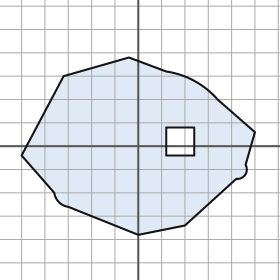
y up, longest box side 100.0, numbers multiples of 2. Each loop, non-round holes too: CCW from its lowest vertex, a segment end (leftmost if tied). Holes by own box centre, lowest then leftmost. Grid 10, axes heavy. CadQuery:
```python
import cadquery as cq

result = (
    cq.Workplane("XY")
    .moveTo(0.0, -38.0)
    .lineTo(20.0, -34.0)
    .lineTo(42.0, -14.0)
    .threePointArc((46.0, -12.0), (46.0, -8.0))
    .lineTo(50.0, 6.0)
    .lineTo(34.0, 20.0)
    .threePointArc((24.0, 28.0), (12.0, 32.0))
    .lineTo(-4.0, 38.0)
    .lineTo(-32.0, 30.0)
    .lineTo(-50.0, -4.0)
    .lineTo(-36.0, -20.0)
    .threePointArc((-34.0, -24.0), (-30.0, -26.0))
    .close()
    .moveTo(12.0, -4.0)
    .lineTo(24.0, -4.0)
    .lineTo(24.0, 8.0)
    .lineTo(12.0, 8.0)
    .close()
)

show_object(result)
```